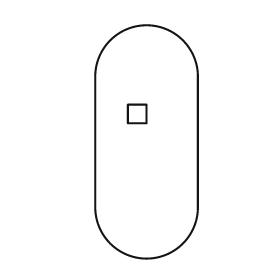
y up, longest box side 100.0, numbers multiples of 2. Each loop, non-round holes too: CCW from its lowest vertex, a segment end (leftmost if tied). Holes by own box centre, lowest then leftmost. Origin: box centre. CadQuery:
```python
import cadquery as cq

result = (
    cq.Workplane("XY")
    .moveTo(-22.0, -28.0)
    .threePointArc((0.0, -50.0), (22.0, -28.0))
    .lineTo(22.0, 28.0)
    .threePointArc((0.0, 50.0), (-22.0, 28.0))
    .close()
    .moveTo(-8.0, 8.0)
    .lineTo(0.0, 8.0)
    .lineTo(0.0, 16.0)
    .lineTo(-8.0, 16.0)
    .close()
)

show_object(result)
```